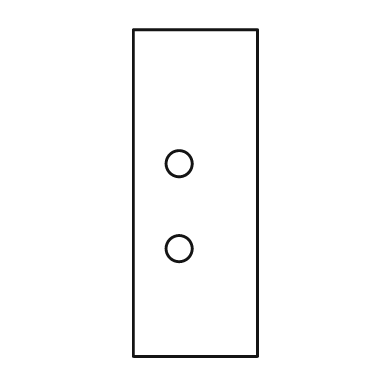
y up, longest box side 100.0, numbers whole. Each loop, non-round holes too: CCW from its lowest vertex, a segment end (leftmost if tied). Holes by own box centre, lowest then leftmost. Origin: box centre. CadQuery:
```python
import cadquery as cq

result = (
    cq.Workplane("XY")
    .moveTo(-19.0, -50.0)
    .lineTo(19.0, -50.0)
    .lineTo(19.0, 50.0)
    .lineTo(-19.0, 50.0)
    .close()
    .moveTo(-5.0, -17.0)
    .circle(4.0)
    .moveTo(-5.0, 9.0)
    .circle(4.0)
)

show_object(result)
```